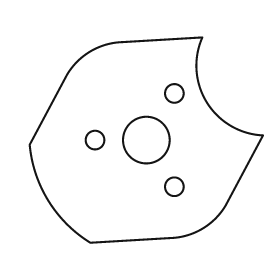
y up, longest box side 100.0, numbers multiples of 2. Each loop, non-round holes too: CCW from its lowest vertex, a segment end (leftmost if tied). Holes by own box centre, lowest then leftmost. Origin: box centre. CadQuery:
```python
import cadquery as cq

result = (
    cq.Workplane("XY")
    .moveTo(-24.0, -44.0)
    .lineTo(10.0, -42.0)
    .threePointArc((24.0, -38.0), (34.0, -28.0))
    .lineTo(50.0, 2.0)
    .threePointArc((26.0, 16.0), (24.0, 44.0))
    .lineTo(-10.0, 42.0)
    .threePointArc((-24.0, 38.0), (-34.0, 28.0))
    .lineTo(-50.0, -2.0)
    .threePointArc((-42.0, -26.0), (-24.0, -44.0))
    .close()
    .moveTo(12.0, -20.0)
    .circle(4.0)
    .moveTo(-22.0, 0.0)
    .circle(4.0)
    .moveTo(0.0, 0.0)
    .circle(10.0)
    .moveTo(12.0, 20.0)
    .circle(4.0)
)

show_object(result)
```